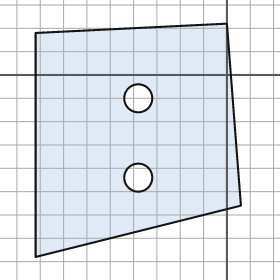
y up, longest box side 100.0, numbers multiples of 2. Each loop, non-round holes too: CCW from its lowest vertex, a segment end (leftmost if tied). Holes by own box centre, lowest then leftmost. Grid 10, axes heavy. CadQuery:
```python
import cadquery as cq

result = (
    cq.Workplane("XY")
    .moveTo(-82.0, -78.0)
    .lineTo(6.0, -56.0)
    .lineTo(0.0, 22.0)
    .lineTo(-82.0, 18.0)
    .close()
    .moveTo(-38.0, -44.0)
    .circle(6.0)
    .moveTo(-38.0, -10.0)
    .circle(6.0)
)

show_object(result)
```